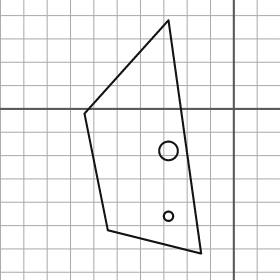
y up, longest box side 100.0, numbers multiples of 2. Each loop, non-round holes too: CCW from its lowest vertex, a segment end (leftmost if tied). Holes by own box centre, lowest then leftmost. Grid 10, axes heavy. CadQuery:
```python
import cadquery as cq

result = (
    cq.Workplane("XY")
    .moveTo(-14.0, -62.0)
    .lineTo(-28.0, 38.0)
    .lineTo(-64.0, -2.0)
    .lineTo(-54.0, -52.0)
    .close()
    .moveTo(-28.0, -46.0)
    .circle(2.0)
    .moveTo(-28.0, -18.0)
    .circle(4.0)
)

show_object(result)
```